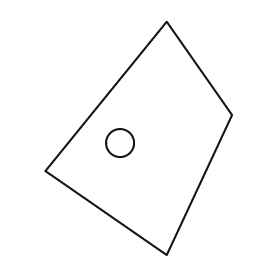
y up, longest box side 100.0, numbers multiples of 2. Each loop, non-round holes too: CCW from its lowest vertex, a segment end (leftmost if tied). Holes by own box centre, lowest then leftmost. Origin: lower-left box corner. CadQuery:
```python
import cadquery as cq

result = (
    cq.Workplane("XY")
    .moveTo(52.0, 0.0)
    .lineTo(80.0, 60.0)
    .lineTo(52.0, 100.0)
    .lineTo(0.0, 36.0)
    .close()
    .moveTo(32.0, 48.0)
    .circle(6.0)
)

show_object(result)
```